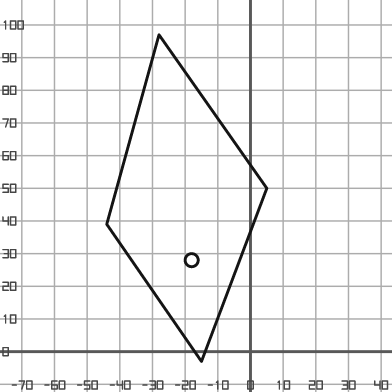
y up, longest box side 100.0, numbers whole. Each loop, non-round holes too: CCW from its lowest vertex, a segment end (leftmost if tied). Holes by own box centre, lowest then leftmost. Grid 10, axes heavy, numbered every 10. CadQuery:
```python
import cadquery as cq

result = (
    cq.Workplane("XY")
    .moveTo(-15.0, -3.0)
    .lineTo(5.0, 50.0)
    .lineTo(-28.0, 97.0)
    .lineTo(-44.0, 39.0)
    .close()
    .moveTo(-18.0, 28.0)
    .circle(2.0)
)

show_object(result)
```